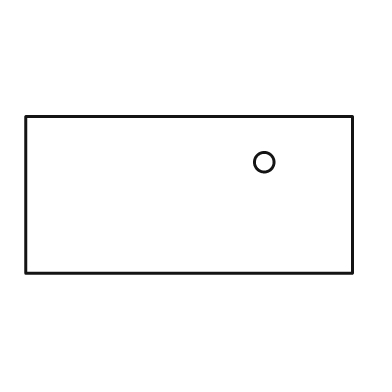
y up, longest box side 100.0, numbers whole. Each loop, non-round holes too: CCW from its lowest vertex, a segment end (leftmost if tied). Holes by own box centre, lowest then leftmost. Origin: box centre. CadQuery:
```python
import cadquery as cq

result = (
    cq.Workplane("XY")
    .moveTo(-50.0, -24.0)
    .lineTo(50.0, -24.0)
    .lineTo(50.0, 24.0)
    .lineTo(-50.0, 24.0)
    .close()
    .moveTo(23.0, 10.0)
    .circle(3.0)
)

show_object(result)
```